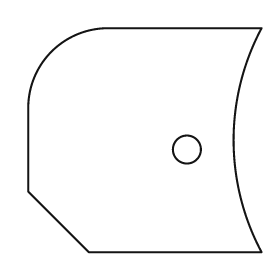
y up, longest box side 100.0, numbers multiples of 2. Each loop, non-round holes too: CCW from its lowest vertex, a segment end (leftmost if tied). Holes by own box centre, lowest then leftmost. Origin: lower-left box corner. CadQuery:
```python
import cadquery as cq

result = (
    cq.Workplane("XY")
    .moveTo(26.0, 0.0)
    .lineTo(100.0, 0.0)
    .threePointArc((88.0, 48.0), (100.0, 96.0))
    .lineTo(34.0, 96.0)
    .threePointArc((10.0, 86.0), (0.0, 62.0))
    .lineTo(0.0, 26.0)
    .close()
    .moveTo(68.0, 44.0)
    .circle(6.0)
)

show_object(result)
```